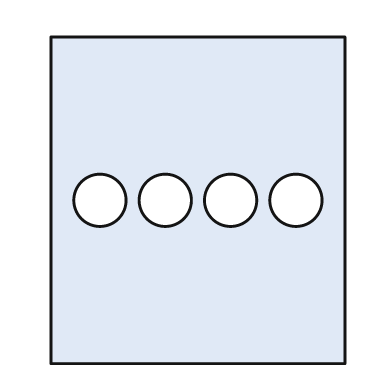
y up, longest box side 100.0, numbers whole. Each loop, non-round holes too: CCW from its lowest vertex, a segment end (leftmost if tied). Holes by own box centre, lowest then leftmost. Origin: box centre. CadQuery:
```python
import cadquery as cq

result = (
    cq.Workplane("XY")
    .moveTo(-45.0, -50.0)
    .lineTo(45.0, -50.0)
    .lineTo(45.0, 50.0)
    .lineTo(-45.0, 50.0)
    .close()
    .moveTo(-30.0, 0.0)
    .circle(8.0)
    .moveTo(-10.0, 0.0)
    .circle(8.0)
    .moveTo(10.0, 0.0)
    .circle(8.0)
    .moveTo(30.0, 0.0)
    .circle(8.0)
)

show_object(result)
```